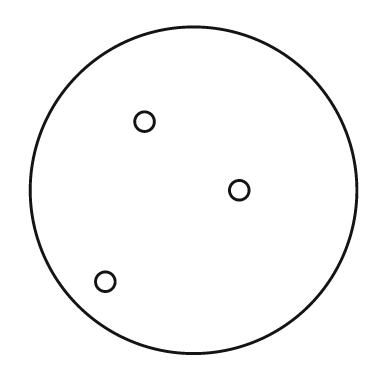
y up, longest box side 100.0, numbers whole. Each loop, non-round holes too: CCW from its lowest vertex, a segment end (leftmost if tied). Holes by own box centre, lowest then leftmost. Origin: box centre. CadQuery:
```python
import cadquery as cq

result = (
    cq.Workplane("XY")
    .moveTo(0.0, 0.0)
    .circle(50.0)
    .moveTo(-27.0, -28.0)
    .circle(3.0)
    .moveTo(14.0, 0.0)
    .circle(3.0)
    .moveTo(-15.0, 21.0)
    .circle(3.0)
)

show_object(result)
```